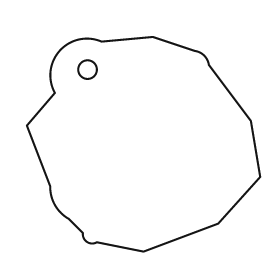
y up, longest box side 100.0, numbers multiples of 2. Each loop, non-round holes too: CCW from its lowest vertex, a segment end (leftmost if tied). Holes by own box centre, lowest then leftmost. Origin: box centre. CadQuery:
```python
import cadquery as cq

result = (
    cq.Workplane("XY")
    .moveTo(0.0, -46.0)
    .lineTo(32.0, -34.0)
    .lineTo(50.0, -14.0)
    .lineTo(46.0, 10.0)
    .lineTo(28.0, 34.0)
    .threePointArc((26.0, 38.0), (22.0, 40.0))
    .lineTo(4.0, 46.0)
    .lineTo(-18.0, 44.0)
    .threePointArc((-36.0, 40.0), (-38.0, 22.0))
    .lineTo(-50.0, 8.0)
    .lineTo(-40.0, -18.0)
    .threePointArc((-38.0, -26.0), (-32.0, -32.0))
    .lineTo(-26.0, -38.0)
    .threePointArc((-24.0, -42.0), (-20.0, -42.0))
    .close()
    .moveTo(-24.0, 32.0)
    .circle(4.0)
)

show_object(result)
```